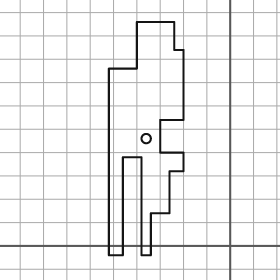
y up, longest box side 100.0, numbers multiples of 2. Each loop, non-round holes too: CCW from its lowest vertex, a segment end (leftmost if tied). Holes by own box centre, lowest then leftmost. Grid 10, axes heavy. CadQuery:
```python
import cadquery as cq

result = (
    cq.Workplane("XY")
    .moveTo(-52.0, -4.0)
    .lineTo(-46.0, -4.0)
    .lineTo(-46.0, 38.0)
    .lineTo(-38.0, 38.0)
    .lineTo(-38.0, -4.0)
    .lineTo(-34.0, -4.0)
    .lineTo(-34.0, 14.0)
    .lineTo(-26.0, 14.0)
    .lineTo(-26.0, 32.0)
    .lineTo(-20.0, 32.0)
    .lineTo(-20.0, 40.0)
    .lineTo(-30.0, 40.0)
    .lineTo(-30.0, 54.0)
    .lineTo(-20.0, 54.0)
    .lineTo(-20.0, 84.0)
    .lineTo(-24.0, 84.0)
    .lineTo(-24.0, 96.0)
    .lineTo(-40.0, 96.0)
    .lineTo(-40.0, 76.0)
    .lineTo(-52.0, 76.0)
    .close()
    .moveTo(-36.0, 46.0)
    .circle(2.0)
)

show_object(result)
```